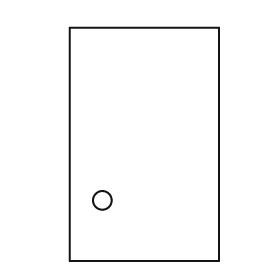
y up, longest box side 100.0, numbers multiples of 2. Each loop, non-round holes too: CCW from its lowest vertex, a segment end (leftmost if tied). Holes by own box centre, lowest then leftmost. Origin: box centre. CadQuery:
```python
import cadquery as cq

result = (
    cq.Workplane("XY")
    .moveTo(-32.0, -50.0)
    .lineTo(32.0, -50.0)
    .lineTo(32.0, 50.0)
    .lineTo(-32.0, 50.0)
    .close()
    .moveTo(-18.0, -24.0)
    .circle(4.0)
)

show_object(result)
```